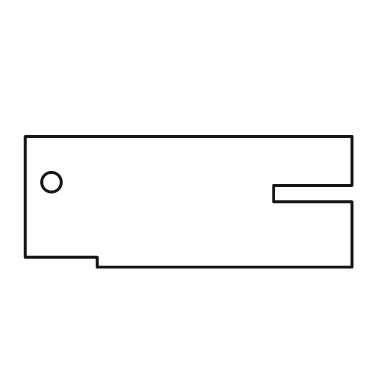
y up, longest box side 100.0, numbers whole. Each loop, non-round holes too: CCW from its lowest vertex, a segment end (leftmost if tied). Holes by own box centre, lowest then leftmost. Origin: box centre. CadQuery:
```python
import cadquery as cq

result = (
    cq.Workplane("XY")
    .moveTo(-28.0, -20.0)
    .lineTo(50.0, -20.0)
    .lineTo(50.0, 0.0)
    .lineTo(26.0, 0.0)
    .lineTo(26.0, 5.0)
    .lineTo(50.0, 5.0)
    .lineTo(50.0, 20.0)
    .lineTo(-50.0, 20.0)
    .lineTo(-50.0, -17.0)
    .lineTo(-28.0, -17.0)
    .close()
    .moveTo(-42.0, 6.0)
    .circle(3.0)
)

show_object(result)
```